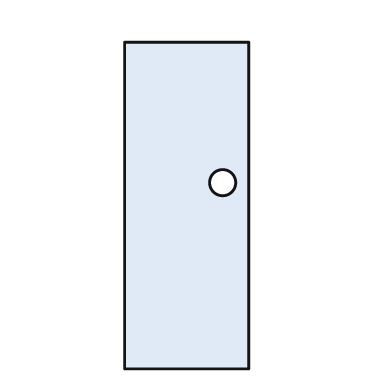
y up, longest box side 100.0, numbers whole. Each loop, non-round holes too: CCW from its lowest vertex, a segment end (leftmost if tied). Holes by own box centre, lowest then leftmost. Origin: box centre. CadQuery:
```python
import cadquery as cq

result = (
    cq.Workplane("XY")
    .moveTo(-19.0, -50.0)
    .lineTo(19.0, -50.0)
    .lineTo(19.0, 50.0)
    .lineTo(-19.0, 50.0)
    .close()
    .moveTo(11.0, 7.0)
    .circle(4.0)
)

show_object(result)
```